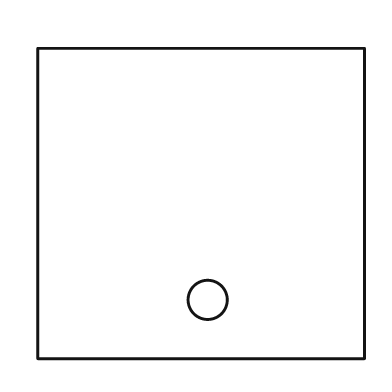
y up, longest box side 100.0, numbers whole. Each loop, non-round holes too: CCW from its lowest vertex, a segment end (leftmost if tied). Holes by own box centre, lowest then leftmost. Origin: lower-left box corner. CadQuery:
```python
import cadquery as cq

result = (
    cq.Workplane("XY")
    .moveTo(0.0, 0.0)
    .lineTo(100.0, 0.0)
    .lineTo(100.0, 95.0)
    .lineTo(0.0, 95.0)
    .close()
    .moveTo(52.0, 18.0)
    .circle(6.0)
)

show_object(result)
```